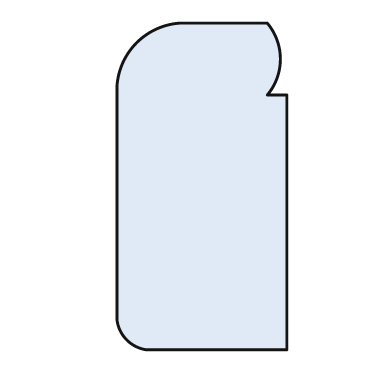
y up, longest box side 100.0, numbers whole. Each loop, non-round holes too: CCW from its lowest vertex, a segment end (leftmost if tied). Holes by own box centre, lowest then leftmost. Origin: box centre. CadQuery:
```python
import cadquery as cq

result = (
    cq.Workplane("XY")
    .moveTo(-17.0, -50.0)
    .lineTo(26.0, -50.0)
    .lineTo(26.0, 28.0)
    .lineTo(20.0, 28.0)
    .threePointArc((24.0, 39.0), (20.0, 50.0))
    .lineTo(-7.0, 50.0)
    .threePointArc((-20.0, 44.0), (-26.0, 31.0))
    .lineTo(-26.0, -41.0)
    .threePointArc((-23.0, -47.0), (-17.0, -50.0))
    .close()
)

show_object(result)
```